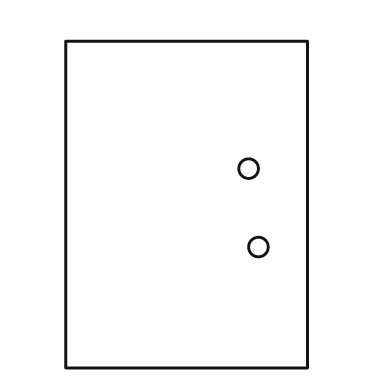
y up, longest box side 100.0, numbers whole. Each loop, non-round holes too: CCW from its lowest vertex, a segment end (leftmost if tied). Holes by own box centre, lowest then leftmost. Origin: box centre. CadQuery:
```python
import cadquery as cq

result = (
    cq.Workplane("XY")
    .moveTo(-37.0, -50.0)
    .lineTo(37.0, -50.0)
    .lineTo(37.0, 50.0)
    .lineTo(-37.0, 50.0)
    .close()
    .moveTo(22.0, -13.0)
    .circle(3.0)
    .moveTo(19.0, 11.0)
    .circle(3.0)
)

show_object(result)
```